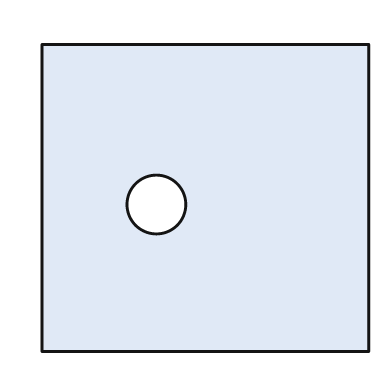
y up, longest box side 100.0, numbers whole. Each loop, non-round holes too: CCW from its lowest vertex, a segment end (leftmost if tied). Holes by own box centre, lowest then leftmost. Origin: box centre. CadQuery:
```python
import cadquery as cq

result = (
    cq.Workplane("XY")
    .moveTo(-50.0, -47.0)
    .lineTo(50.0, -47.0)
    .lineTo(50.0, 47.0)
    .lineTo(-50.0, 47.0)
    .close()
    .moveTo(-15.0, -2.0)
    .circle(9.0)
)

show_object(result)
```